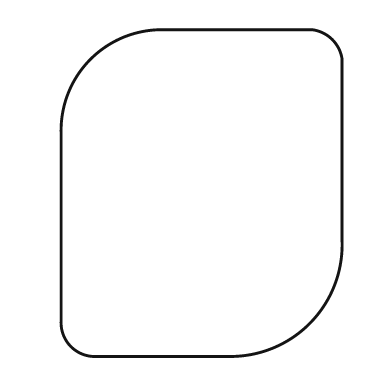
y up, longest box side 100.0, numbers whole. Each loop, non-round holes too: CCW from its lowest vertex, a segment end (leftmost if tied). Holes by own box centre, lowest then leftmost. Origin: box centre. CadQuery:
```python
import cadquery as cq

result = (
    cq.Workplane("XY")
    .moveTo(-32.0, -50.0)
    .lineTo(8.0, -50.0)
    .threePointArc((33.0, -40.0), (43.0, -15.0))
    .lineTo(43.0, 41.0)
    .threePointArc((40.0, 47.0), (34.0, 50.0))
    .lineTo(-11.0, 50.0)
    .threePointArc((-34.0, 41.0), (-43.0, 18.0))
    .lineTo(-43.0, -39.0)
    .threePointArc((-40.0, -47.0), (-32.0, -50.0))
    .close()
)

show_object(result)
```